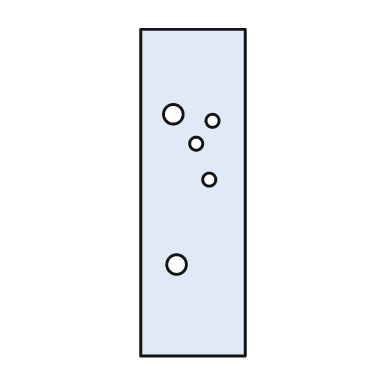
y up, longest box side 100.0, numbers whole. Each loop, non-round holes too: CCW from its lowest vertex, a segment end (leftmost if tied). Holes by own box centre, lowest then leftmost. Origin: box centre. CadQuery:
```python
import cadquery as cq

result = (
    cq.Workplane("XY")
    .moveTo(-16.0, -50.0)
    .lineTo(16.0, -50.0)
    .lineTo(16.0, 50.0)
    .lineTo(-16.0, 50.0)
    .close()
    .moveTo(-5.0, -22.0)
    .circle(3.0)
    .moveTo(5.0, 4.0)
    .circle(2.0)
    .moveTo(1.0, 15.0)
    .circle(2.0)
    .moveTo(6.0, 22.0)
    .circle(2.0)
    .moveTo(-6.0, 24.0)
    .circle(3.0)
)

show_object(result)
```